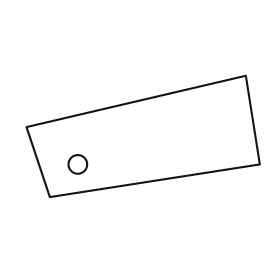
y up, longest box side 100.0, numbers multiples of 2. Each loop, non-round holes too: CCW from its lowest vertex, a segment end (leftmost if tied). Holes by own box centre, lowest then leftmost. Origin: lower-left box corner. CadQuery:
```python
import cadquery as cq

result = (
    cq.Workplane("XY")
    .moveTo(10.0, 0.0)
    .lineTo(100.0, 14.0)
    .lineTo(94.0, 52.0)
    .lineTo(0.0, 30.0)
    .close()
    .moveTo(22.0, 14.0)
    .circle(4.0)
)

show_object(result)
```